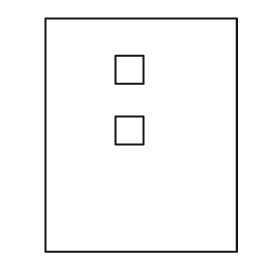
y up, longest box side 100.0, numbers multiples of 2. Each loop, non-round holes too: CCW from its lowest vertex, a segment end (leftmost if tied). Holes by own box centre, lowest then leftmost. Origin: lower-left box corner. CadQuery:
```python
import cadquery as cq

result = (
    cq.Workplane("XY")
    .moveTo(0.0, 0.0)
    .lineTo(82.0, 0.0)
    .lineTo(82.0, 100.0)
    .lineTo(0.0, 100.0)
    .close()
    .moveTo(30.0, 46.0)
    .lineTo(42.0, 46.0)
    .lineTo(42.0, 58.0)
    .lineTo(30.0, 58.0)
    .close()
    .moveTo(30.0, 72.0)
    .lineTo(42.0, 72.0)
    .lineTo(42.0, 84.0)
    .lineTo(30.0, 84.0)
    .close()
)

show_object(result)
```